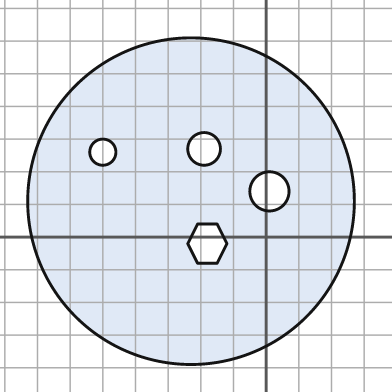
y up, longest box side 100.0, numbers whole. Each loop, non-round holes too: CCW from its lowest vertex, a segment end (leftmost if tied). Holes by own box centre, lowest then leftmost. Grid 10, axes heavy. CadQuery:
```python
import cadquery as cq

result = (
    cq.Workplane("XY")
    .moveTo(-23.0, 11.0)
    .circle(50.0)
    .moveTo(-21.0, -8.0)
    .lineTo(-15.0, -8.0)
    .lineTo(-12.0, -2.0)
    .lineTo(-15.0, 4.0)
    .lineTo(-21.0, 4.0)
    .lineTo(-24.0, -2.0)
    .close()
    .moveTo(1.0, 14.0)
    .circle(6.0)
    .moveTo(-50.0, 26.0)
    .circle(4.0)
    .moveTo(-19.0, 27.0)
    .circle(5.0)
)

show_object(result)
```